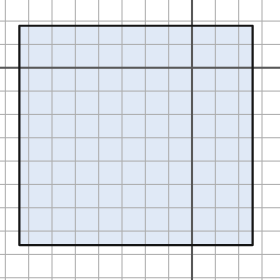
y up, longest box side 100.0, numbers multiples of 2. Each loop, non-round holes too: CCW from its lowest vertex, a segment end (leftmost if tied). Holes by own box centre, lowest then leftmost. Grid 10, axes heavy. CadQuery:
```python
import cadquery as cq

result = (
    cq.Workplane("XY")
    .moveTo(-74.0, -76.0)
    .lineTo(26.0, -76.0)
    .lineTo(26.0, 18.0)
    .lineTo(-74.0, 18.0)
    .close()
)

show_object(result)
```